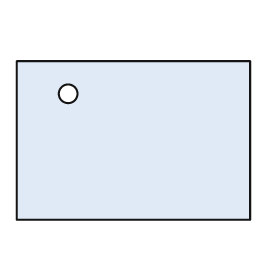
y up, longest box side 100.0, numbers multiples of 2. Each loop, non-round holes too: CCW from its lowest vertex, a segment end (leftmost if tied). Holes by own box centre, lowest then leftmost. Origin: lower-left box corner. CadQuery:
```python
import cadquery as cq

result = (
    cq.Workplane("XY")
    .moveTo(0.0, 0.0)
    .lineTo(100.0, 0.0)
    .lineTo(100.0, 68.0)
    .lineTo(0.0, 68.0)
    .close()
    .moveTo(22.0, 54.0)
    .circle(4.0)
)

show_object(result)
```